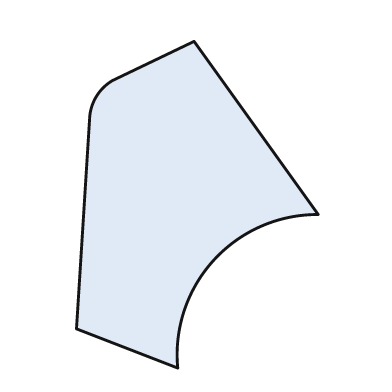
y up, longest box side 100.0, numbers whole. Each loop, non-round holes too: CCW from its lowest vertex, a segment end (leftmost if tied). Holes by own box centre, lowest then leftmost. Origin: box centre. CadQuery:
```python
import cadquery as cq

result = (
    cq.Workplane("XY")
    .moveTo(-6.0, -50.0)
    .threePointArc((5.0, -17.0), (37.0, -3.0))
    .lineTo(-1.0, 50.0)
    .lineTo(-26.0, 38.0)
    .threePointArc((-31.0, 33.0), (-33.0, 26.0))
    .lineTo(-37.0, -38.0)
    .close()
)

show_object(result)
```